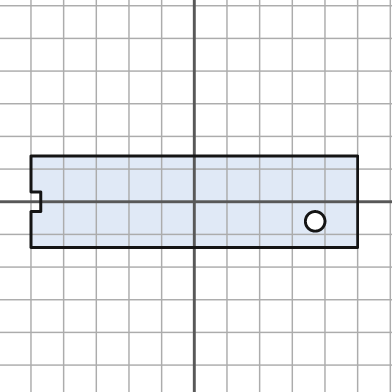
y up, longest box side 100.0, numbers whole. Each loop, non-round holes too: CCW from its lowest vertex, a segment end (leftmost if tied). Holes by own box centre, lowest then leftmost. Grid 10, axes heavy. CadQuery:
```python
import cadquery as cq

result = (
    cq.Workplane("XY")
    .moveTo(-50.0, -14.0)
    .lineTo(50.0, -14.0)
    .lineTo(50.0, 14.0)
    .lineTo(-50.0, 14.0)
    .lineTo(-50.0, 3.0)
    .lineTo(-47.0, 3.0)
    .lineTo(-47.0, -3.0)
    .lineTo(-50.0, -3.0)
    .close()
    .moveTo(37.0, -6.0)
    .circle(3.0)
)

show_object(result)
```